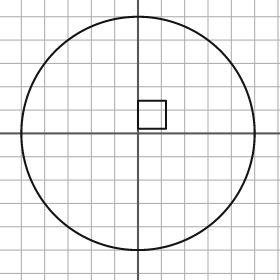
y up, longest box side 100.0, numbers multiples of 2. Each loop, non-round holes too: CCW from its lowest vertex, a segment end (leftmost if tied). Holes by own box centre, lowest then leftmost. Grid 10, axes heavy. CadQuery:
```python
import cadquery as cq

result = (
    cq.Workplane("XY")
    .moveTo(0.0, 0.0)
    .circle(50.0)
    .moveTo(0.0, 2.0)
    .lineTo(12.0, 2.0)
    .lineTo(12.0, 14.0)
    .lineTo(0.0, 14.0)
    .close()
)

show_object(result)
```